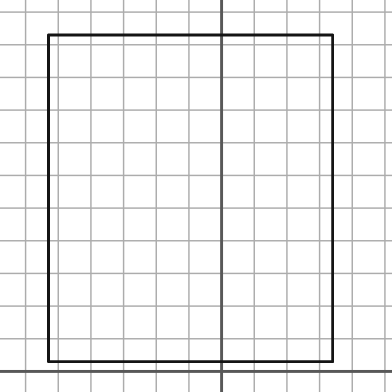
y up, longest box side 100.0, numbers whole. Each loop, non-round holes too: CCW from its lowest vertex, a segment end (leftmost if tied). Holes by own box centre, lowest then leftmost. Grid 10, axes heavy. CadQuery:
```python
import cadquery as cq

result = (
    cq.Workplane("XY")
    .moveTo(-53.0, 3.0)
    .lineTo(34.0, 3.0)
    .lineTo(34.0, 103.0)
    .lineTo(-53.0, 103.0)
    .close()
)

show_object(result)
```